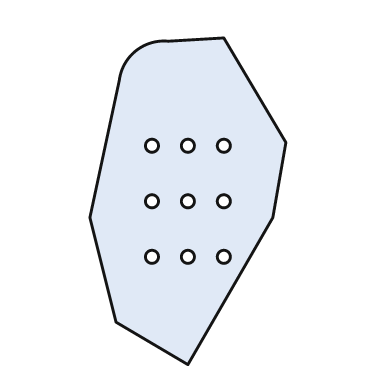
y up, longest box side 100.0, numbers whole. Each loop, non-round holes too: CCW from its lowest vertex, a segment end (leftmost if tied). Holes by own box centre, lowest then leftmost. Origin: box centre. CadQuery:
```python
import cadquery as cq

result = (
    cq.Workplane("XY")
    .moveTo(0.0, -50.0)
    .lineTo(26.0, -5.0)
    .lineTo(30.0, 18.0)
    .lineTo(11.0, 50.0)
    .lineTo(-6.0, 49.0)
    .threePointArc((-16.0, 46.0), (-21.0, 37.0))
    .lineTo(-30.0, -5.0)
    .lineTo(-22.0, -37.0)
    .close()
    .moveTo(-11.0, -17.0)
    .circle(2.0)
    .moveTo(0.0, -17.0)
    .circle(2.0)
    .moveTo(11.0, -17.0)
    .circle(2.0)
    .moveTo(-11.0, 0.0)
    .circle(2.0)
    .moveTo(0.0, 0.0)
    .circle(2.0)
    .moveTo(11.0, 0.0)
    .circle(2.0)
    .moveTo(-11.0, 17.0)
    .circle(2.0)
    .moveTo(0.0, 17.0)
    .circle(2.0)
    .moveTo(11.0, 17.0)
    .circle(2.0)
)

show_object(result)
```